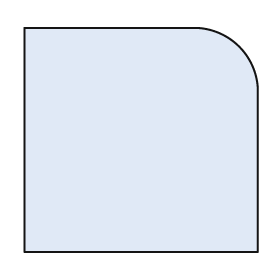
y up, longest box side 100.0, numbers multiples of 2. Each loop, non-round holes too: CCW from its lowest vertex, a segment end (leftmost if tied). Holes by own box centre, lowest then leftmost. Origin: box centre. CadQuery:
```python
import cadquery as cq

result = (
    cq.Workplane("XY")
    .moveTo(-50.0, -48.0)
    .lineTo(50.0, -48.0)
    .lineTo(50.0, 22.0)
    .threePointArc((42.0, 40.0), (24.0, 48.0))
    .lineTo(-50.0, 48.0)
    .close()
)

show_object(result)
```